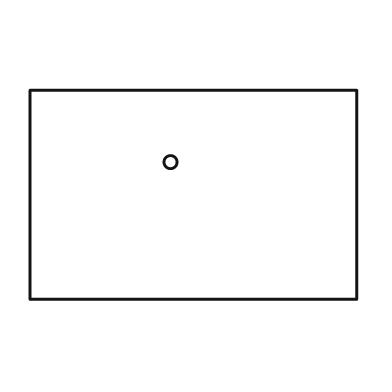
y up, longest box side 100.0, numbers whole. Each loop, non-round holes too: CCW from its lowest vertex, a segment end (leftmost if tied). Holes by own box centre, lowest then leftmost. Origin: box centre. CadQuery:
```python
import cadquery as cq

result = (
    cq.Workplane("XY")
    .moveTo(-50.0, -32.0)
    .lineTo(50.0, -32.0)
    .lineTo(50.0, 32.0)
    .lineTo(-50.0, 32.0)
    .close()
    .moveTo(-7.0, 10.0)
    .circle(2.0)
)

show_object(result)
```